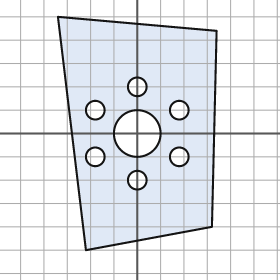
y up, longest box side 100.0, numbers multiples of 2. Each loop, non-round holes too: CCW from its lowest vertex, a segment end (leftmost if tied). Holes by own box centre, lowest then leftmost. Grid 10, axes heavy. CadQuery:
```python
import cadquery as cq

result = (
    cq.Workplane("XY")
    .moveTo(-22.0, -50.0)
    .lineTo(32.0, -40.0)
    .lineTo(34.0, 44.0)
    .lineTo(-34.0, 50.0)
    .close()
    .moveTo(0.0, -20.0)
    .circle(4.0)
    .moveTo(-18.0, -10.0)
    .circle(4.0)
    .moveTo(18.0, -10.0)
    .circle(4.0)
    .moveTo(0.0, 0.0)
    .circle(10.0)
    .moveTo(-18.0, 10.0)
    .circle(4.0)
    .moveTo(18.0, 10.0)
    .circle(4.0)
    .moveTo(0.0, 20.0)
    .circle(4.0)
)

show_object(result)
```